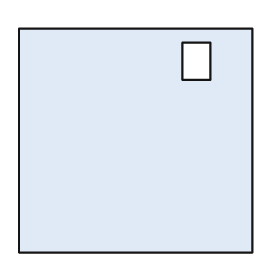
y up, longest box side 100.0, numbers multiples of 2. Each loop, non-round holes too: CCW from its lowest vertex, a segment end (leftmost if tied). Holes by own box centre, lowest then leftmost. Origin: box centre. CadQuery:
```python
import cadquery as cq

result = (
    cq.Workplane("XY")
    .moveTo(-50.0, -48.0)
    .lineTo(50.0, -48.0)
    .lineTo(50.0, 48.0)
    .lineTo(-50.0, 48.0)
    .close()
    .moveTo(20.0, 26.0)
    .lineTo(32.0, 26.0)
    .lineTo(32.0, 42.0)
    .lineTo(20.0, 42.0)
    .close()
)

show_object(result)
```